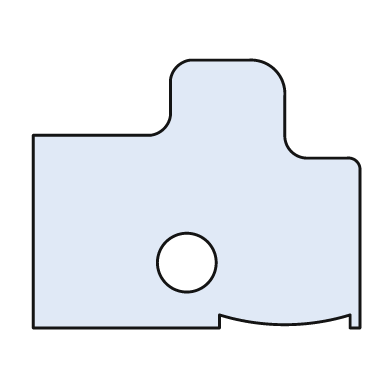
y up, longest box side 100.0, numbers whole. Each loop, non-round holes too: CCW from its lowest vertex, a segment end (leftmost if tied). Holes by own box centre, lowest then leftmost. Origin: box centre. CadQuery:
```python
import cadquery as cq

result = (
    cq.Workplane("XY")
    .moveTo(-50.0, -41.0)
    .lineTo(7.0, -41.0)
    .lineTo(7.0, -37.0)
    .threePointArc((27.0, -40.0), (47.0, -37.0))
    .lineTo(47.0, -41.0)
    .lineTo(50.0, -41.0)
    .lineTo(50.0, 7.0)
    .threePointArc((49.0, 10.0), (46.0, 11.0))
    .lineTo(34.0, 11.0)
    .threePointArc((29.0, 13.0), (27.0, 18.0))
    .lineTo(27.0, 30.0)
    .threePointArc((24.0, 38.0), (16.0, 41.0))
    .lineTo(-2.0, 41.0)
    .threePointArc((-6.0, 39.0), (-8.0, 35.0))
    .lineTo(-8.0, 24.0)
    .threePointArc((-10.0, 20.0), (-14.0, 18.0))
    .lineTo(-50.0, 18.0)
    .close()
    .moveTo(-3.0, -21.0)
    .circle(9.0)
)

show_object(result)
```